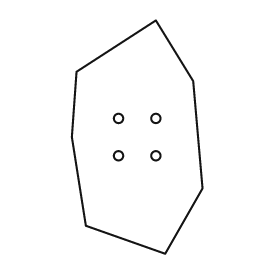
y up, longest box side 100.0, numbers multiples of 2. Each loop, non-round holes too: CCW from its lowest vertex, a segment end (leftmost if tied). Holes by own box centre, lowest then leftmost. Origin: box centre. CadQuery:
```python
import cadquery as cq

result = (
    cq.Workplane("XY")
    .moveTo(12.0, -50.0)
    .lineTo(28.0, -22.0)
    .lineTo(24.0, 24.0)
    .lineTo(8.0, 50.0)
    .lineTo(-26.0, 28.0)
    .lineTo(-28.0, 0.0)
    .lineTo(-22.0, -38.0)
    .close()
    .moveTo(-8.0, -8.0)
    .circle(2.0)
    .moveTo(8.0, -8.0)
    .circle(2.0)
    .moveTo(-8.0, 8.0)
    .circle(2.0)
    .moveTo(8.0, 8.0)
    .circle(2.0)
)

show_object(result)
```